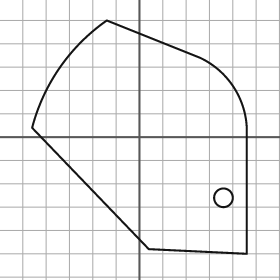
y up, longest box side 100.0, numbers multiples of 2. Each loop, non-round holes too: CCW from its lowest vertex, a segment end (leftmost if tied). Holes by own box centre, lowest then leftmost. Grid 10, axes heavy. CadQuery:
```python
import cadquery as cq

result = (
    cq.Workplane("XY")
    .moveTo(46.0, -50.0)
    .lineTo(46.0, 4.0)
    .threePointArc((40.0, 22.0), (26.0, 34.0))
    .lineTo(-14.0, 50.0)
    .threePointArc((-34.0, 30.0), (-46.0, 4.0))
    .lineTo(4.0, -48.0)
    .close()
    .moveTo(36.0, -26.0)
    .circle(4.0)
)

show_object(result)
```